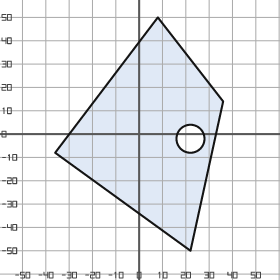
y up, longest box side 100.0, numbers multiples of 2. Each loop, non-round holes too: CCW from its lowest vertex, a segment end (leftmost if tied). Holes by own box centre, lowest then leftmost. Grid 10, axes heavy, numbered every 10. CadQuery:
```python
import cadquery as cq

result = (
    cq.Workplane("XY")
    .moveTo(22.0, -50.0)
    .lineTo(36.0, 14.0)
    .lineTo(8.0, 50.0)
    .lineTo(-36.0, -8.0)
    .close()
    .moveTo(22.0, -2.0)
    .circle(6.0)
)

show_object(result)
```